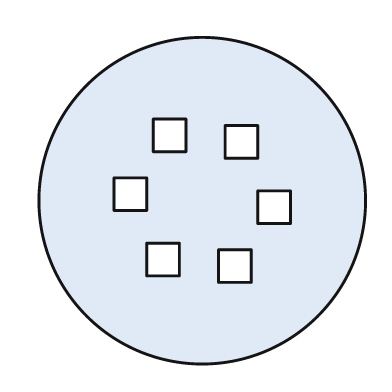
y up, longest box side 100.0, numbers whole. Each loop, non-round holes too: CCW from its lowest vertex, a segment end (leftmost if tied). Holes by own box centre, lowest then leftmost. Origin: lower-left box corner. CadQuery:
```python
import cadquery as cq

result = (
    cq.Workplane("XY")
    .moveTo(50.0, 50.0)
    .circle(50.0)
    .moveTo(55.0, 25.0)
    .lineTo(65.0, 25.0)
    .lineTo(65.0, 35.0)
    .lineTo(55.0, 35.0)
    .close()
    .moveTo(33.0, 27.0)
    .lineTo(43.0, 27.0)
    .lineTo(43.0, 37.0)
    .lineTo(33.0, 37.0)
    .close()
    .moveTo(67.0, 43.0)
    .lineTo(77.0, 43.0)
    .lineTo(77.0, 53.0)
    .lineTo(67.0, 53.0)
    .close()
    .moveTo(23.0, 47.0)
    .lineTo(33.0, 47.0)
    .lineTo(33.0, 57.0)
    .lineTo(23.0, 57.0)
    .close()
    .moveTo(57.0, 63.0)
    .lineTo(67.0, 63.0)
    .lineTo(67.0, 73.0)
    .lineTo(57.0, 73.0)
    .close()
    .moveTo(35.0, 65.0)
    .lineTo(45.0, 65.0)
    .lineTo(45.0, 75.0)
    .lineTo(35.0, 75.0)
    .close()
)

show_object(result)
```